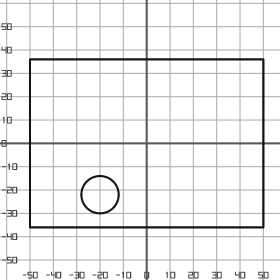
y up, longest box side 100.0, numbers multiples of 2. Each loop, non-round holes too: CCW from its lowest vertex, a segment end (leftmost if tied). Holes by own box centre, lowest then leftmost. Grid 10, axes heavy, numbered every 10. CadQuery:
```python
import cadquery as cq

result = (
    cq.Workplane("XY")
    .moveTo(-50.0, -36.0)
    .lineTo(50.0, -36.0)
    .lineTo(50.0, 36.0)
    .lineTo(-50.0, 36.0)
    .close()
    .moveTo(-20.0, -22.0)
    .circle(8.0)
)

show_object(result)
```